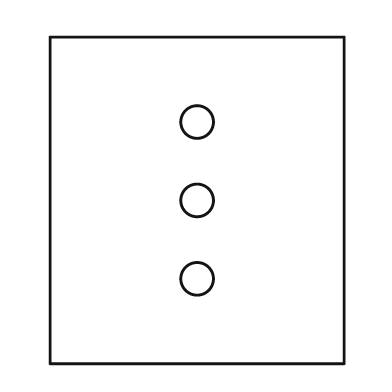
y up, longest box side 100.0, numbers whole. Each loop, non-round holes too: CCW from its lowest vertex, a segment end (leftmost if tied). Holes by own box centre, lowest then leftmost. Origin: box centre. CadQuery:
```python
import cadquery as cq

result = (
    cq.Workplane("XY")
    .moveTo(-45.0, -50.0)
    .lineTo(45.0, -50.0)
    .lineTo(45.0, 50.0)
    .lineTo(-45.0, 50.0)
    .close()
    .moveTo(0.0, -24.0)
    .circle(5.0)
    .moveTo(0.0, 0.0)
    .circle(5.0)
    .moveTo(0.0, 24.0)
    .circle(5.0)
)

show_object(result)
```